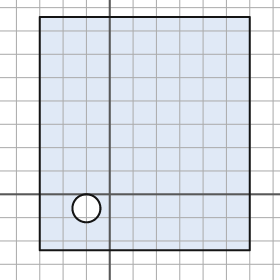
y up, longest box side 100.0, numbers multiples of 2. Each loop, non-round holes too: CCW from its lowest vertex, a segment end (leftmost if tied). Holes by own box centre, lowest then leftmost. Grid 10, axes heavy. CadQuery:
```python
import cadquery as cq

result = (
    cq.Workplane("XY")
    .moveTo(-30.0, -24.0)
    .lineTo(60.0, -24.0)
    .lineTo(60.0, 76.0)
    .lineTo(-30.0, 76.0)
    .close()
    .moveTo(-10.0, -6.0)
    .circle(6.0)
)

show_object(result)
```